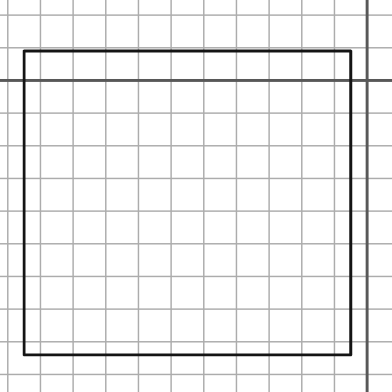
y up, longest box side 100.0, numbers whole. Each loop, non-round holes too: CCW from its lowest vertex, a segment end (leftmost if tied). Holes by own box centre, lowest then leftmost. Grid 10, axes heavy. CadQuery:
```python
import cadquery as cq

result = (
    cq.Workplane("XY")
    .moveTo(-105.0, -84.0)
    .lineTo(-5.0, -84.0)
    .lineTo(-5.0, 9.0)
    .lineTo(-105.0, 9.0)
    .close()
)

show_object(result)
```